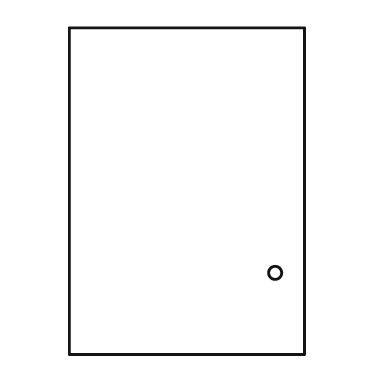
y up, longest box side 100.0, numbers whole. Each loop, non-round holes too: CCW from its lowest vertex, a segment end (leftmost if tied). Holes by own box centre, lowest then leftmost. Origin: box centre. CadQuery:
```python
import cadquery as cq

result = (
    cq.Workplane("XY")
    .moveTo(-36.0, -50.0)
    .lineTo(36.0, -50.0)
    .lineTo(36.0, 50.0)
    .lineTo(-36.0, 50.0)
    .close()
    .moveTo(27.0, -25.0)
    .circle(2.0)
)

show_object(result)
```